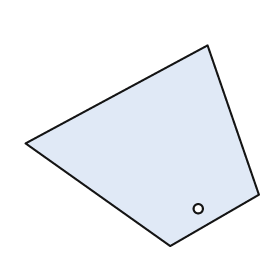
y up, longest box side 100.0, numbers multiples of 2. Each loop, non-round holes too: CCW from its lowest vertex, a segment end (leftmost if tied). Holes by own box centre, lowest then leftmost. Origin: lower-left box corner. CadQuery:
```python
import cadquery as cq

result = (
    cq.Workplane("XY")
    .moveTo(62.0, 0.0)
    .lineTo(100.0, 22.0)
    .lineTo(78.0, 86.0)
    .lineTo(0.0, 44.0)
    .close()
    .moveTo(74.0, 16.0)
    .circle(2.0)
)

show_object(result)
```